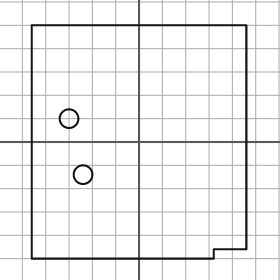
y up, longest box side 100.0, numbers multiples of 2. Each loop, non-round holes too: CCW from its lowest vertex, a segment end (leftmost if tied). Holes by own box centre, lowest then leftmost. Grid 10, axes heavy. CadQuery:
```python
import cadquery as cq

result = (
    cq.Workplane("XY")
    .moveTo(-46.0, -50.0)
    .lineTo(32.0, -50.0)
    .lineTo(32.0, -46.0)
    .lineTo(46.0, -46.0)
    .lineTo(46.0, 50.0)
    .lineTo(-46.0, 50.0)
    .close()
    .moveTo(-24.0, -14.0)
    .circle(4.0)
    .moveTo(-30.0, 10.0)
    .circle(4.0)
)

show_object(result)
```